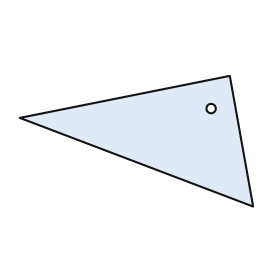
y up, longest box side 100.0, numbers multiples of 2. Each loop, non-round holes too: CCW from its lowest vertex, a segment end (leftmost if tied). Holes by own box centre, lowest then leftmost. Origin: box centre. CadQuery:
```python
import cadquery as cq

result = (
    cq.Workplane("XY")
    .moveTo(50.0, -28.0)
    .lineTo(40.0, 28.0)
    .lineTo(-50.0, 10.0)
    .close()
    .moveTo(32.0, 14.0)
    .circle(2.0)
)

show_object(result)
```